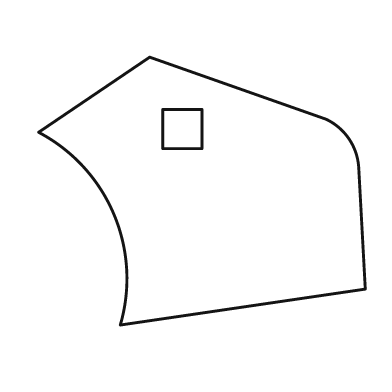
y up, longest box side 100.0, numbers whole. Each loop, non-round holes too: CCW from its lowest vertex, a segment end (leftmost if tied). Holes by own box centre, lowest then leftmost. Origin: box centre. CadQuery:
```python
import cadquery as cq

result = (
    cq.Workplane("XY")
    .moveTo(-25.0, -41.0)
    .lineTo(50.0, -30.0)
    .lineTo(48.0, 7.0)
    .threePointArc((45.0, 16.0), (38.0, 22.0))
    .lineTo(-16.0, 41.0)
    .lineTo(-50.0, 18.0)
    .threePointArc((-27.0, -7.0), (-25.0, -41.0))
    .close()
    .moveTo(-12.0, 13.0)
    .lineTo(0.0, 13.0)
    .lineTo(0.0, 25.0)
    .lineTo(-12.0, 25.0)
    .close()
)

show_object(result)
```